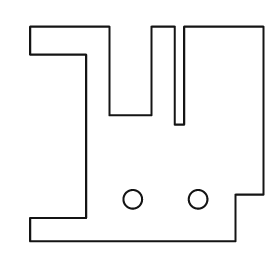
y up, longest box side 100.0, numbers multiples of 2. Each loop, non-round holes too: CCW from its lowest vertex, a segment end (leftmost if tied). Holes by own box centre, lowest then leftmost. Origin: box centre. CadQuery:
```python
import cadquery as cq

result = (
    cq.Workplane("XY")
    .moveTo(-50.0, -46.0)
    .lineTo(38.0, -46.0)
    .lineTo(38.0, -26.0)
    .lineTo(50.0, -26.0)
    .lineTo(50.0, 46.0)
    .lineTo(16.0, 46.0)
    .lineTo(16.0, 4.0)
    .lineTo(12.0, 4.0)
    .lineTo(12.0, 46.0)
    .lineTo(2.0, 46.0)
    .lineTo(2.0, 8.0)
    .lineTo(-16.0, 8.0)
    .lineTo(-16.0, 46.0)
    .lineTo(-50.0, 46.0)
    .lineTo(-50.0, 34.0)
    .lineTo(-26.0, 34.0)
    .lineTo(-26.0, -36.0)
    .lineTo(-50.0, -36.0)
    .close()
    .moveTo(-6.0, -28.0)
    .circle(4.0)
    .moveTo(22.0, -28.0)
    .circle(4.0)
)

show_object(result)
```